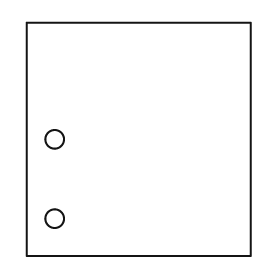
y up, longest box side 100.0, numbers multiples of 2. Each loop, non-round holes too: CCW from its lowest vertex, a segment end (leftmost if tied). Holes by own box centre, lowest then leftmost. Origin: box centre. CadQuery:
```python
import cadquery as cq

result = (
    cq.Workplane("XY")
    .moveTo(-48.0, -50.0)
    .lineTo(48.0, -50.0)
    .lineTo(48.0, 50.0)
    .lineTo(-48.0, 50.0)
    .close()
    .moveTo(-36.0, -34.0)
    .circle(4.0)
    .moveTo(-36.0, 0.0)
    .circle(4.0)
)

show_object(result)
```